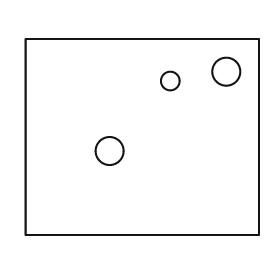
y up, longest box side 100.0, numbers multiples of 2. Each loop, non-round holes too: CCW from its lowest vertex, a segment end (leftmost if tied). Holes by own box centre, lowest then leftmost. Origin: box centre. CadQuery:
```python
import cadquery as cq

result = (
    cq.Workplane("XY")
    .moveTo(-50.0, -42.0)
    .lineTo(50.0, -42.0)
    .lineTo(50.0, 42.0)
    .lineTo(-50.0, 42.0)
    .close()
    .moveTo(-14.0, -6.0)
    .circle(6.0)
    .moveTo(12.0, 24.0)
    .circle(4.0)
    .moveTo(36.0, 28.0)
    .circle(6.0)
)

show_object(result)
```